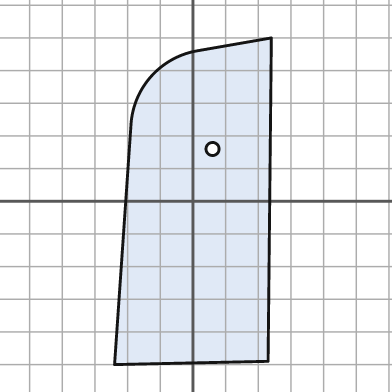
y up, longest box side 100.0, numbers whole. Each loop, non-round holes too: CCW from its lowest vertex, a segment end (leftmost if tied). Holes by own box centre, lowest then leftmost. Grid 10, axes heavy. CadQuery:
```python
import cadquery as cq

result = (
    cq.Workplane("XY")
    .moveTo(-24.0, -50.0)
    .lineTo(23.0, -49.0)
    .lineTo(24.0, 50.0)
    .lineTo(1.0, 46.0)
    .threePointArc((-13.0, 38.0), (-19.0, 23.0))
    .close()
    .moveTo(6.0, 16.0)
    .circle(2.0)
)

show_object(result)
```